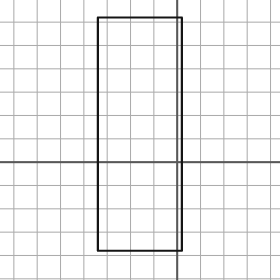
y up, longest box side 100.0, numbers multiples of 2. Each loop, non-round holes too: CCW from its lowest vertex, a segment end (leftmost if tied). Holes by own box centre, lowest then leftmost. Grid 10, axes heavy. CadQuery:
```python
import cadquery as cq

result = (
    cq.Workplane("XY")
    .moveTo(-34.0, -38.0)
    .lineTo(2.0, -38.0)
    .lineTo(2.0, 62.0)
    .lineTo(-34.0, 62.0)
    .close()
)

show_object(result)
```